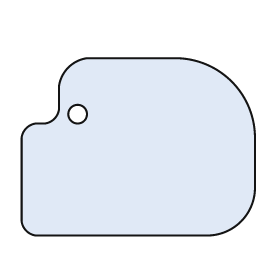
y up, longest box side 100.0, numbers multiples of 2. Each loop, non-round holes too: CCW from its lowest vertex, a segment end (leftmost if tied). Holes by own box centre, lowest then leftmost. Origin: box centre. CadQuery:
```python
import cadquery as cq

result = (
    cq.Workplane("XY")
    .moveTo(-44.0, -38.0)
    .lineTo(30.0, -38.0)
    .threePointArc((44.0, -32.0), (50.0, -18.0))
    .lineTo(50.0, 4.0)
    .threePointArc((40.0, 28.0), (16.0, 38.0))
    .lineTo(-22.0, 38.0)
    .threePointArc((-30.0, 34.0), (-34.0, 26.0))
    .lineTo(-34.0, 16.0)
    .threePointArc((-36.0, 12.0), (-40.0, 10.0))
    .lineTo(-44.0, 10.0)
    .threePointArc((-48.0, 8.0), (-50.0, 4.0))
    .lineTo(-50.0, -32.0)
    .threePointArc((-48.0, -36.0), (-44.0, -38.0))
    .close()
    .moveTo(-26.0, 14.0)
    .circle(4.0)
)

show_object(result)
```